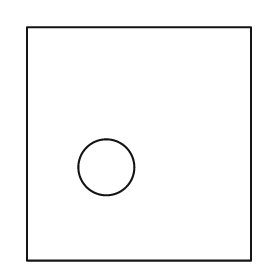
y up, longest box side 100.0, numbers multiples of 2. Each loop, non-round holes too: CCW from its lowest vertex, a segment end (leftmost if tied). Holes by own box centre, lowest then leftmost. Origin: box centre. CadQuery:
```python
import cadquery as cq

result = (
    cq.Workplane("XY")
    .moveTo(-48.0, -50.0)
    .lineTo(48.0, -50.0)
    .lineTo(48.0, 50.0)
    .lineTo(-48.0, 50.0)
    .close()
    .moveTo(-14.0, -10.0)
    .circle(12.0)
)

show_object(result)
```